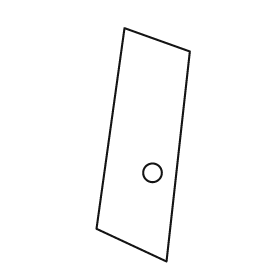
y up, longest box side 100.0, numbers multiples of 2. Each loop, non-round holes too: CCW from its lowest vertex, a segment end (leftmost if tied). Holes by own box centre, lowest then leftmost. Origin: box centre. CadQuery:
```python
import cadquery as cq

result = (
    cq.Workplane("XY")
    .moveTo(10.0, -50.0)
    .lineTo(20.0, 40.0)
    .lineTo(-8.0, 50.0)
    .lineTo(-20.0, -36.0)
    .close()
    .moveTo(4.0, -12.0)
    .circle(4.0)
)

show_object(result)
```